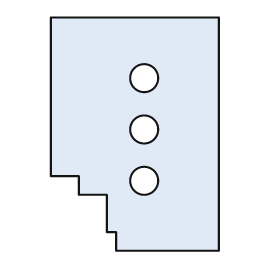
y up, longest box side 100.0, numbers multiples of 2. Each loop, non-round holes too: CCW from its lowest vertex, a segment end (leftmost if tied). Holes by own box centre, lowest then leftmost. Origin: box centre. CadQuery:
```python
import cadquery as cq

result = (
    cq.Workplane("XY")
    .moveTo(-8.0, -50.0)
    .lineTo(36.0, -50.0)
    .lineTo(36.0, 50.0)
    .lineTo(-36.0, 50.0)
    .lineTo(-36.0, -18.0)
    .lineTo(-24.0, -18.0)
    .lineTo(-24.0, -26.0)
    .lineTo(-12.0, -26.0)
    .lineTo(-12.0, -42.0)
    .lineTo(-8.0, -42.0)
    .close()
    .moveTo(4.0, -20.0)
    .circle(6.0)
    .moveTo(4.0, 2.0)
    .circle(6.0)
    .moveTo(4.0, 24.0)
    .circle(6.0)
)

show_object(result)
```